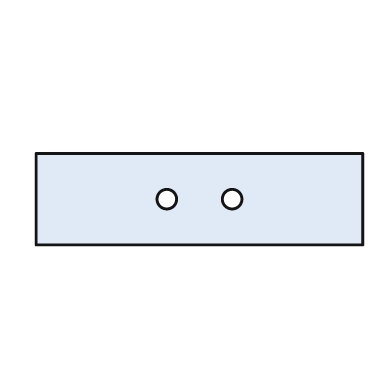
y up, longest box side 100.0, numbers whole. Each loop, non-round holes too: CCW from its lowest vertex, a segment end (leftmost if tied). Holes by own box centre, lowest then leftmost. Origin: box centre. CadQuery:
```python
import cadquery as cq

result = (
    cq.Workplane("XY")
    .moveTo(-50.0, -14.0)
    .lineTo(50.0, -14.0)
    .lineTo(50.0, 14.0)
    .lineTo(-50.0, 14.0)
    .close()
    .moveTo(-10.0, 0.0)
    .circle(3.0)
    .moveTo(10.0, 0.0)
    .circle(3.0)
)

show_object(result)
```